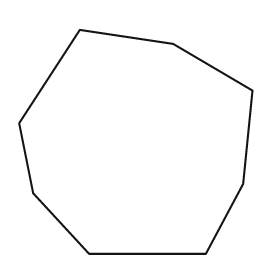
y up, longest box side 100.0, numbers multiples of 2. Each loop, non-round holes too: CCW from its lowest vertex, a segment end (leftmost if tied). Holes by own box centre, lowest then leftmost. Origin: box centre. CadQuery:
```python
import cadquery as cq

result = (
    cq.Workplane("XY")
    .moveTo(-20.0, -48.0)
    .lineTo(30.0, -48.0)
    .lineTo(46.0, -18.0)
    .lineTo(50.0, 22.0)
    .lineTo(16.0, 42.0)
    .lineTo(-24.0, 48.0)
    .lineTo(-50.0, 8.0)
    .lineTo(-44.0, -22.0)
    .close()
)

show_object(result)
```